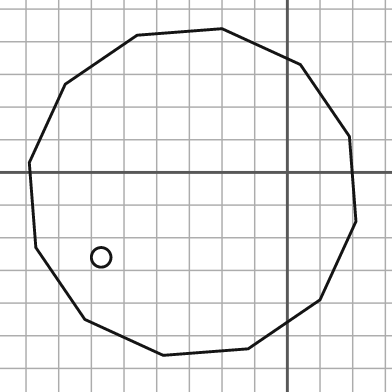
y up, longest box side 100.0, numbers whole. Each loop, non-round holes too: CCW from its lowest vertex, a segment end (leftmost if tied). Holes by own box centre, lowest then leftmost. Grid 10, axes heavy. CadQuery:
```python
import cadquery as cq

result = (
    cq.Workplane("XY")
    .moveTo(-38.0, -56.0)
    .lineTo(-12.0, -54.0)
    .lineTo(10.0, -39.0)
    .lineTo(21.0, -15.0)
    .lineTo(19.0, 11.0)
    .lineTo(4.0, 33.0)
    .lineTo(-20.0, 44.0)
    .lineTo(-46.0, 42.0)
    .lineTo(-68.0, 27.0)
    .lineTo(-79.0, 3.0)
    .lineTo(-77.0, -23.0)
    .lineTo(-62.0, -45.0)
    .close()
    .moveTo(-57.0, -26.0)
    .circle(3.0)
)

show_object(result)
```